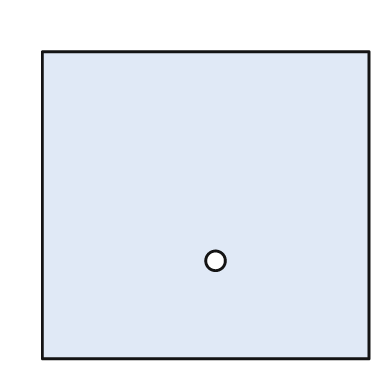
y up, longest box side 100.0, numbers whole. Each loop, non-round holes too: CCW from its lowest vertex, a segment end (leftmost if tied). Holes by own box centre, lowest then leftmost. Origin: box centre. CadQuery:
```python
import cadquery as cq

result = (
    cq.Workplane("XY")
    .moveTo(-50.0, -47.0)
    .lineTo(50.0, -47.0)
    .lineTo(50.0, 47.0)
    .lineTo(-50.0, 47.0)
    .close()
    .moveTo(3.0, -17.0)
    .circle(3.0)
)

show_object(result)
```